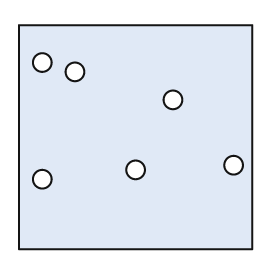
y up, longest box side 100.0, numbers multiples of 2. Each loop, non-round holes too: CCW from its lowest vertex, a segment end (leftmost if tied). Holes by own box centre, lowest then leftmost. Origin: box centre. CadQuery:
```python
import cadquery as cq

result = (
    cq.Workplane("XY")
    .moveTo(-50.0, -48.0)
    .lineTo(50.0, -48.0)
    .lineTo(50.0, 48.0)
    .lineTo(-50.0, 48.0)
    .close()
    .moveTo(-40.0, -18.0)
    .circle(4.0)
    .moveTo(0.0, -14.0)
    .circle(4.0)
    .moveTo(42.0, -12.0)
    .circle(4.0)
    .moveTo(16.0, 16.0)
    .circle(4.0)
    .moveTo(-26.0, 28.0)
    .circle(4.0)
    .moveTo(-40.0, 32.0)
    .circle(4.0)
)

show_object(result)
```